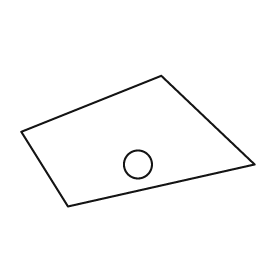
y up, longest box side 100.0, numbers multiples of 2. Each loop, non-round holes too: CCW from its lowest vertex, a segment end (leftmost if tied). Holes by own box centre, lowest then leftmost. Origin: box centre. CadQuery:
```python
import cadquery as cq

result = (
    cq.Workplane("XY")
    .moveTo(-30.0, -28.0)
    .lineTo(50.0, -10.0)
    .lineTo(10.0, 28.0)
    .lineTo(-50.0, 4.0)
    .close()
    .moveTo(0.0, -10.0)
    .circle(6.0)
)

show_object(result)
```